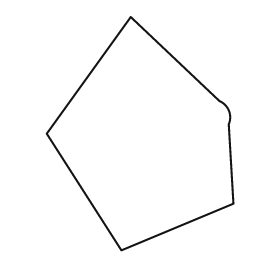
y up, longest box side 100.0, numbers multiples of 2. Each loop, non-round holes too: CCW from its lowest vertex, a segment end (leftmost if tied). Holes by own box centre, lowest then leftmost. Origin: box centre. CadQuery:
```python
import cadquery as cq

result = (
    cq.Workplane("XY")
    .moveTo(-8.0, -50.0)
    .lineTo(40.0, -30.0)
    .lineTo(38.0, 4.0)
    .threePointArc((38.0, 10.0), (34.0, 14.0))
    .lineTo(-4.0, 50.0)
    .lineTo(-40.0, 0.0)
    .close()
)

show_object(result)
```